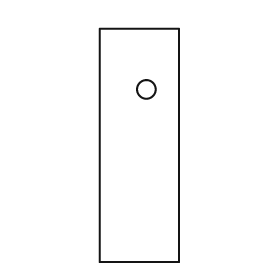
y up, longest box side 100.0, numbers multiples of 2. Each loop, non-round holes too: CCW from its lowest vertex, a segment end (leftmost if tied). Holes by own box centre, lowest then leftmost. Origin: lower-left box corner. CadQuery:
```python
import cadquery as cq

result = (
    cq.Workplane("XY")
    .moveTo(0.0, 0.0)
    .lineTo(34.0, 0.0)
    .lineTo(34.0, 100.0)
    .lineTo(0.0, 100.0)
    .close()
    .moveTo(20.0, 74.0)
    .circle(4.0)
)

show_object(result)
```